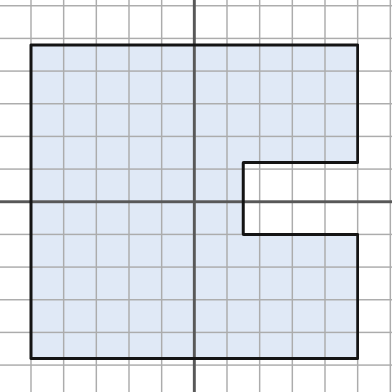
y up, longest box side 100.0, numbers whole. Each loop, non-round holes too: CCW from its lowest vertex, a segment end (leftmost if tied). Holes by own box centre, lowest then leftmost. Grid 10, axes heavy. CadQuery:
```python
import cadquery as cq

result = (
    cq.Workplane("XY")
    .moveTo(-50.0, -48.0)
    .lineTo(50.0, -48.0)
    .lineTo(50.0, -10.0)
    .lineTo(15.0, -10.0)
    .lineTo(15.0, 12.0)
    .lineTo(50.0, 12.0)
    .lineTo(50.0, 48.0)
    .lineTo(-50.0, 48.0)
    .close()
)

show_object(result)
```